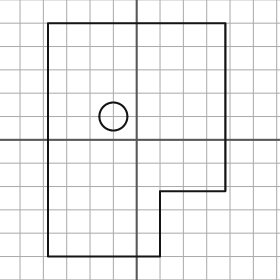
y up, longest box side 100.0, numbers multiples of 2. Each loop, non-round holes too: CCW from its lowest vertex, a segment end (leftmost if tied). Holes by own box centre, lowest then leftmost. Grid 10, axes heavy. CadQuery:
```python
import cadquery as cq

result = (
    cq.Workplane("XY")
    .moveTo(-38.0, -50.0)
    .lineTo(10.0, -50.0)
    .lineTo(10.0, -22.0)
    .lineTo(38.0, -22.0)
    .lineTo(38.0, 50.0)
    .lineTo(-38.0, 50.0)
    .close()
    .moveTo(-10.0, 10.0)
    .circle(6.0)
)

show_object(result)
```